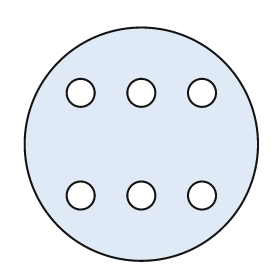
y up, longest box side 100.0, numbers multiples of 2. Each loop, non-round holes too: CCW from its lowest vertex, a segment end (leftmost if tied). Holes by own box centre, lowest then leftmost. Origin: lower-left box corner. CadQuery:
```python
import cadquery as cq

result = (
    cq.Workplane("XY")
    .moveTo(50.0, 50.0)
    .circle(50.0)
    .moveTo(24.0, 28.0)
    .circle(6.0)
    .moveTo(50.0, 28.0)
    .circle(6.0)
    .moveTo(76.0, 28.0)
    .circle(6.0)
    .moveTo(24.0, 72.0)
    .circle(6.0)
    .moveTo(50.0, 72.0)
    .circle(6.0)
    .moveTo(76.0, 72.0)
    .circle(6.0)
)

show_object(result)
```